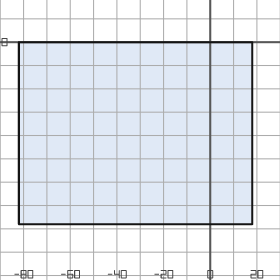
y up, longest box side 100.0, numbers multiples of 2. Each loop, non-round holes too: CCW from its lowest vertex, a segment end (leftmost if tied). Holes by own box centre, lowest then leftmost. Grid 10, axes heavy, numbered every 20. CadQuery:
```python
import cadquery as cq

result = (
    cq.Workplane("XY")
    .moveTo(-82.0, -78.0)
    .lineTo(18.0, -78.0)
    .lineTo(18.0, 0.0)
    .lineTo(-82.0, 0.0)
    .close()
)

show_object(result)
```